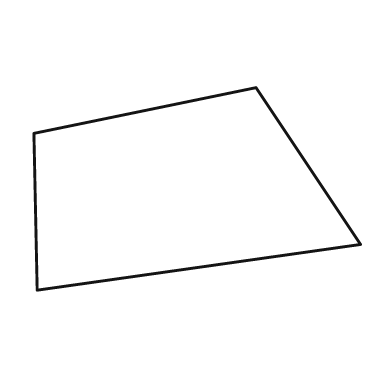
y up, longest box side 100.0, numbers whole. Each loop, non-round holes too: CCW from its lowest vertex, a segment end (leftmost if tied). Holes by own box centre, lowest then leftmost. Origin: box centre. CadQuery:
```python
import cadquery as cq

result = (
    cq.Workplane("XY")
    .moveTo(-49.0, -31.0)
    .lineTo(50.0, -17.0)
    .lineTo(18.0, 31.0)
    .lineTo(-50.0, 17.0)
    .close()
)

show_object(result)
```